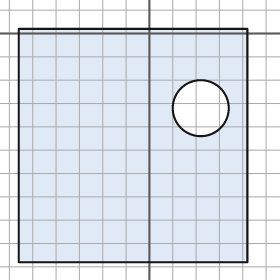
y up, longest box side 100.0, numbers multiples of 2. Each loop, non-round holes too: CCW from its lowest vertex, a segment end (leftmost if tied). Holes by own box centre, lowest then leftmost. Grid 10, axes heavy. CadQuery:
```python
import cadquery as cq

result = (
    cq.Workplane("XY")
    .moveTo(-56.0, -98.0)
    .lineTo(42.0, -98.0)
    .lineTo(42.0, 2.0)
    .lineTo(-56.0, 2.0)
    .close()
    .moveTo(22.0, -32.0)
    .circle(12.0)
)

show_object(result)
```